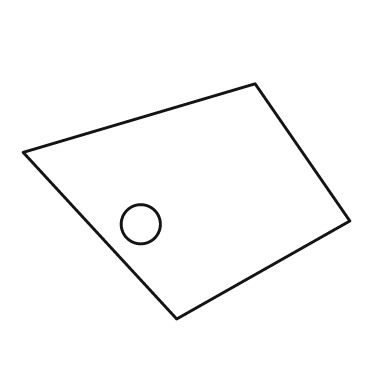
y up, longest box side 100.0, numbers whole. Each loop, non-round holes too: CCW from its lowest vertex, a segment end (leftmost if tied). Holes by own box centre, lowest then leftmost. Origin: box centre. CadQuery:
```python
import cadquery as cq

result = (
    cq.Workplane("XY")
    .moveTo(-3.0, -36.0)
    .lineTo(50.0, -6.0)
    .lineTo(21.0, 36.0)
    .lineTo(-50.0, 15.0)
    .close()
    .moveTo(-14.0, -7.0)
    .circle(6.0)
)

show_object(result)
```